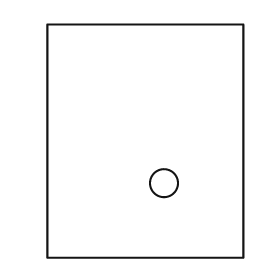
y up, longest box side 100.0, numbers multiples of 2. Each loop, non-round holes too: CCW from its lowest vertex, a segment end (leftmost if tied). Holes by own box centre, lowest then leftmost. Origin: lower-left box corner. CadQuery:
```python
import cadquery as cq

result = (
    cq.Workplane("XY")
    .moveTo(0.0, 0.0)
    .lineTo(84.0, 0.0)
    .lineTo(84.0, 100.0)
    .lineTo(0.0, 100.0)
    .close()
    .moveTo(50.0, 32.0)
    .circle(6.0)
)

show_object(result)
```